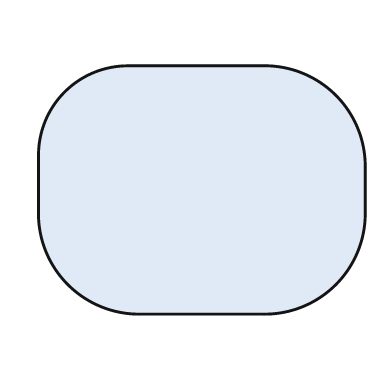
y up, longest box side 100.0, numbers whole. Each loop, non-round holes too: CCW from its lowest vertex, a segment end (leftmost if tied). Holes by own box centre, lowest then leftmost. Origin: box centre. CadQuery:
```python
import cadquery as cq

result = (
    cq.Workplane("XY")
    .moveTo(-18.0, -38.0)
    .lineTo(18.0, -38.0)
    .threePointArc((41.0, -29.0), (50.0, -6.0))
    .lineTo(50.0, 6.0)
    .threePointArc((41.0, 29.0), (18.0, 38.0))
    .lineTo(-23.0, 38.0)
    .threePointArc((-42.0, 30.0), (-50.0, 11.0))
    .lineTo(-50.0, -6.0)
    .threePointArc((-41.0, -29.0), (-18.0, -38.0))
    .close()
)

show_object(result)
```